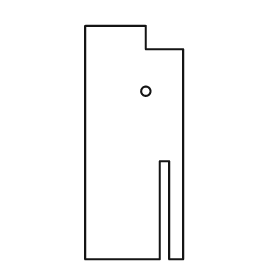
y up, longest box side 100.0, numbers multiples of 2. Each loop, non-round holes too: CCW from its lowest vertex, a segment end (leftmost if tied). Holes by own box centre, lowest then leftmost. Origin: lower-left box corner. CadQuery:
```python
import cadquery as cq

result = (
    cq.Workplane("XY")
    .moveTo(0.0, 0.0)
    .lineTo(32.0, 0.0)
    .lineTo(32.0, 42.0)
    .lineTo(36.0, 42.0)
    .lineTo(36.0, 0.0)
    .lineTo(42.0, 0.0)
    .lineTo(42.0, 90.0)
    .lineTo(26.0, 90.0)
    .lineTo(26.0, 100.0)
    .lineTo(0.0, 100.0)
    .close()
    .moveTo(26.0, 72.0)
    .circle(2.0)
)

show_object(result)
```